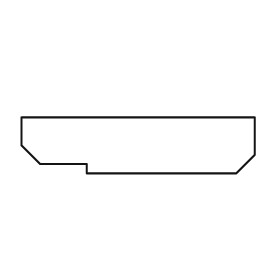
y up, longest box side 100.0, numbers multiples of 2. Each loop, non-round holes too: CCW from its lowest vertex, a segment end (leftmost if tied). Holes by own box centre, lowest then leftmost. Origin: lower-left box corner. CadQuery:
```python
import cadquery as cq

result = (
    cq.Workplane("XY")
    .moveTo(28.0, 0.0)
    .lineTo(92.0, 0.0)
    .lineTo(100.0, 8.0)
    .lineTo(100.0, 24.0)
    .lineTo(0.0, 24.0)
    .lineTo(0.0, 12.0)
    .lineTo(8.0, 4.0)
    .lineTo(28.0, 4.0)
    .close()
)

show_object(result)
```